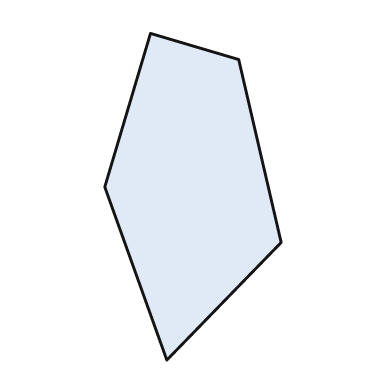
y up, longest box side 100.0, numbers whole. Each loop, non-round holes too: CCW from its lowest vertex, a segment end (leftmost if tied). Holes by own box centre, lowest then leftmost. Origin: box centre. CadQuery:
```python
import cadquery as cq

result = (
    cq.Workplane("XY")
    .moveTo(-8.0, -50.0)
    .lineTo(27.0, -14.0)
    .lineTo(14.0, 42.0)
    .lineTo(-13.0, 50.0)
    .lineTo(-27.0, 3.0)
    .close()
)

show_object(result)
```